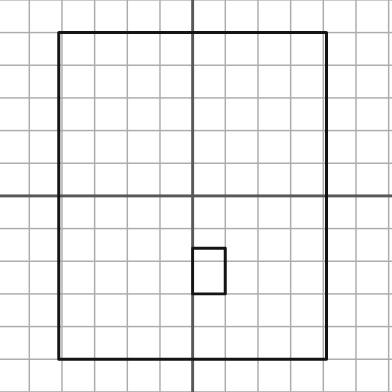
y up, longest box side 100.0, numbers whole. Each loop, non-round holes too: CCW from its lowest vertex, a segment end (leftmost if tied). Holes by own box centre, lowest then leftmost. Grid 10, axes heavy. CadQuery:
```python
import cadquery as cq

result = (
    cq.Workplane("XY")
    .moveTo(-41.0, -50.0)
    .lineTo(41.0, -50.0)
    .lineTo(41.0, 50.0)
    .lineTo(-41.0, 50.0)
    .close()
    .moveTo(0.0, -30.0)
    .lineTo(10.0, -30.0)
    .lineTo(10.0, -16.0)
    .lineTo(0.0, -16.0)
    .close()
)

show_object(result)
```